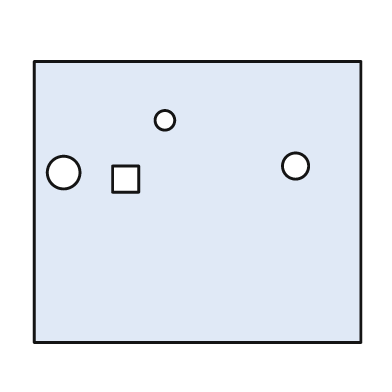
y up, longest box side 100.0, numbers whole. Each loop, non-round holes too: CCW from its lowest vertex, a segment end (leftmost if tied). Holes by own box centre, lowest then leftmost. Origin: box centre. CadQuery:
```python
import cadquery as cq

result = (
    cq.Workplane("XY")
    .moveTo(-50.0, -43.0)
    .lineTo(50.0, -43.0)
    .lineTo(50.0, 43.0)
    .lineTo(-50.0, 43.0)
    .close()
    .moveTo(-26.0, 3.0)
    .lineTo(-18.0, 3.0)
    .lineTo(-18.0, 11.0)
    .lineTo(-26.0, 11.0)
    .close()
    .moveTo(-41.0, 9.0)
    .circle(5.0)
    .moveTo(30.0, 11.0)
    .circle(4.0)
    .moveTo(-10.0, 25.0)
    .circle(3.0)
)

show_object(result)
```